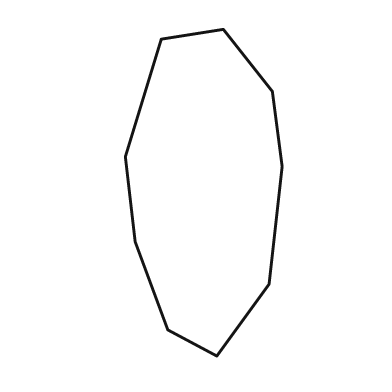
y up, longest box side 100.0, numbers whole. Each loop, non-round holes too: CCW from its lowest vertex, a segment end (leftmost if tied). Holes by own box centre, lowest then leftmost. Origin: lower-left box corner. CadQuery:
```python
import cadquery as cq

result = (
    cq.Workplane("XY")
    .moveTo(28.0, 0.0)
    .lineTo(44.0, 22.0)
    .lineTo(48.0, 58.0)
    .lineTo(45.0, 81.0)
    .lineTo(30.0, 100.0)
    .lineTo(11.0, 97.0)
    .lineTo(0.0, 61.0)
    .lineTo(3.0, 35.0)
    .lineTo(13.0, 8.0)
    .close()
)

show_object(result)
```